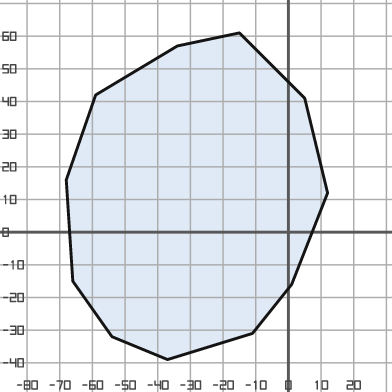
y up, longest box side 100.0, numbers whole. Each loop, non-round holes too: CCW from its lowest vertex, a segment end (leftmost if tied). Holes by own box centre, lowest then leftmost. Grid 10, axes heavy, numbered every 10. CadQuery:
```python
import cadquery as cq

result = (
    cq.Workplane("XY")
    .moveTo(-37.0, -39.0)
    .lineTo(-11.0, -31.0)
    .lineTo(1.0, -16.0)
    .lineTo(12.0, 12.0)
    .lineTo(5.0, 41.0)
    .lineTo(-15.0, 61.0)
    .lineTo(-34.0, 57.0)
    .lineTo(-59.0, 42.0)
    .lineTo(-68.0, 16.0)
    .lineTo(-66.0, -15.0)
    .lineTo(-54.0, -32.0)
    .close()
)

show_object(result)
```